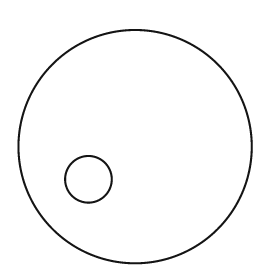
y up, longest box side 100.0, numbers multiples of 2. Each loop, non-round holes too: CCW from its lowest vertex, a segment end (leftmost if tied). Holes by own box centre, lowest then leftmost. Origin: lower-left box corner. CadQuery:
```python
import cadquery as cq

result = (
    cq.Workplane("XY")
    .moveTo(50.0, 50.0)
    .circle(50.0)
    .moveTo(30.0, 36.0)
    .circle(10.0)
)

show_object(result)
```